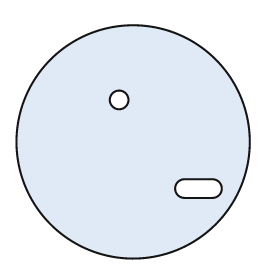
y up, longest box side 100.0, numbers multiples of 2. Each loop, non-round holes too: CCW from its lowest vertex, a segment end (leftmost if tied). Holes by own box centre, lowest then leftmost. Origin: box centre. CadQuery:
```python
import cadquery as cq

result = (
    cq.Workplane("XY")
    .moveTo(0.0, 0.0)
    .circle(50.0)
    .moveTo(22.0, -24.0)
    .lineTo(34.0, -24.0)
    .threePointArc((38.0, -20.0), (34.0, -16.0))
    .lineTo(22.0, -16.0)
    .threePointArc((18.0, -20.0), (22.0, -24.0))
    .close()
    .moveTo(-6.0, 18.0)
    .circle(4.0)
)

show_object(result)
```